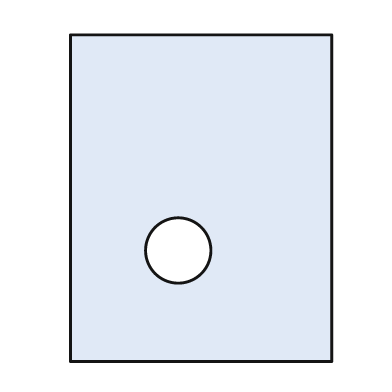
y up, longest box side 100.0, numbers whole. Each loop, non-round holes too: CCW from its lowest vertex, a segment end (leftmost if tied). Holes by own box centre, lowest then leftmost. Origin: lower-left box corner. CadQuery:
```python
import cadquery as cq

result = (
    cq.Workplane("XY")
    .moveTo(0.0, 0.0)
    .lineTo(80.0, 0.0)
    .lineTo(80.0, 100.0)
    .lineTo(0.0, 100.0)
    .close()
    .moveTo(33.0, 34.0)
    .circle(10.0)
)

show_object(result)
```